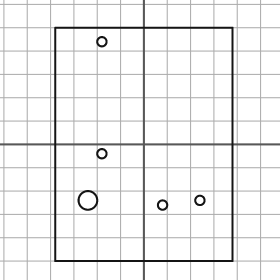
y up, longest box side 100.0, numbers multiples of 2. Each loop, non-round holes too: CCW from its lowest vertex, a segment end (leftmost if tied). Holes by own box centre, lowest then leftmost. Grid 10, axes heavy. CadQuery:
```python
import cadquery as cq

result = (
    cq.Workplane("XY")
    .moveTo(-38.0, -50.0)
    .lineTo(38.0, -50.0)
    .lineTo(38.0, 50.0)
    .lineTo(-38.0, 50.0)
    .close()
    .moveTo(8.0, -26.0)
    .circle(2.0)
    .moveTo(-24.0, -24.0)
    .circle(4.0)
    .moveTo(24.0, -24.0)
    .circle(2.0)
    .moveTo(-18.0, -4.0)
    .circle(2.0)
    .moveTo(-18.0, 44.0)
    .circle(2.0)
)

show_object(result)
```